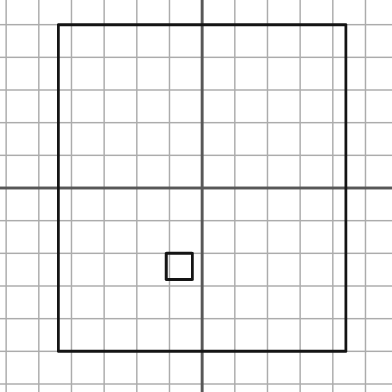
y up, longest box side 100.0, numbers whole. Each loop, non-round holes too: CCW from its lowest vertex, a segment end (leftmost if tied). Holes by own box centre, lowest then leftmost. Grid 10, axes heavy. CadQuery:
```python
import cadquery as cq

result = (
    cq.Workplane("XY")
    .moveTo(-44.0, -50.0)
    .lineTo(44.0, -50.0)
    .lineTo(44.0, 50.0)
    .lineTo(-44.0, 50.0)
    .close()
    .moveTo(-11.0, -28.0)
    .lineTo(-3.0, -28.0)
    .lineTo(-3.0, -20.0)
    .lineTo(-11.0, -20.0)
    .close()
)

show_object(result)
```